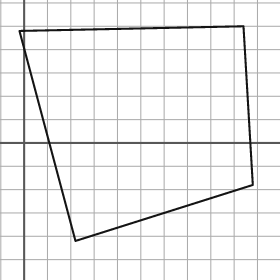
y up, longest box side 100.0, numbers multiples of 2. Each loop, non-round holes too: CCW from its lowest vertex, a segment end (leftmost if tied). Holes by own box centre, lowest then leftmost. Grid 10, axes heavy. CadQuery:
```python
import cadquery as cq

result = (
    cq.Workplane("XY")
    .moveTo(22.0, -42.0)
    .lineTo(98.0, -18.0)
    .lineTo(94.0, 50.0)
    .lineTo(-2.0, 48.0)
    .close()
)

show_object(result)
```